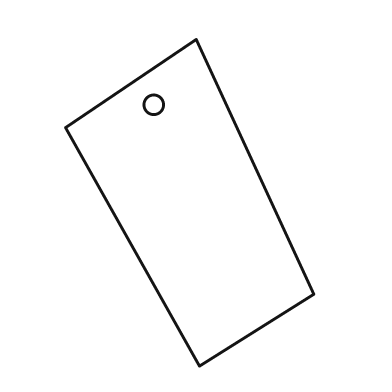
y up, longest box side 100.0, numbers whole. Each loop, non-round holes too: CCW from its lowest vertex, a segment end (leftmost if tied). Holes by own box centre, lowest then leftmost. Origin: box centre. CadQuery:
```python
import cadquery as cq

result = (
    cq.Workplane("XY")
    .moveTo(3.0, -50.0)
    .lineTo(38.0, -28.0)
    .lineTo(2.0, 50.0)
    .lineTo(-38.0, 23.0)
    .close()
    .moveTo(-11.0, 30.0)
    .circle(3.0)
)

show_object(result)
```